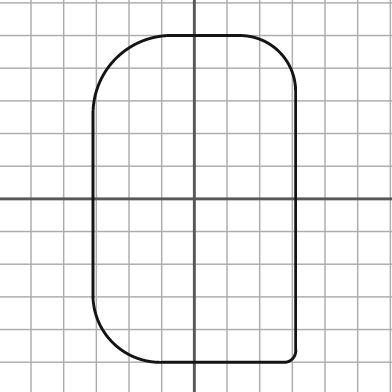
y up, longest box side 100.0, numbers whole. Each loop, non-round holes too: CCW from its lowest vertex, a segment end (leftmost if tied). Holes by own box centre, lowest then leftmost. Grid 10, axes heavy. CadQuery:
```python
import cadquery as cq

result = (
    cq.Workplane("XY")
    .moveTo(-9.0, -50.0)
    .lineTo(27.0, -50.0)
    .threePointArc((30.0, -49.0), (31.0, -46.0))
    .lineTo(31.0, 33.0)
    .threePointArc((26.0, 45.0), (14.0, 50.0))
    .lineTo(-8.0, 50.0)
    .threePointArc((-24.0, 43.0), (-31.0, 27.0))
    .lineTo(-31.0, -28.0)
    .threePointArc((-25.0, -44.0), (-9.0, -50.0))
    .close()
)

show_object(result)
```